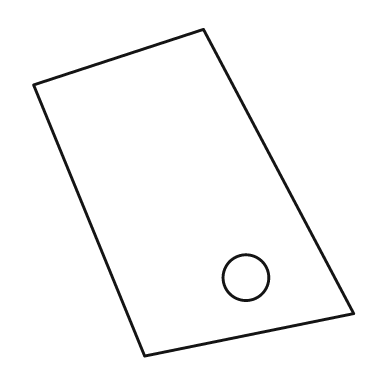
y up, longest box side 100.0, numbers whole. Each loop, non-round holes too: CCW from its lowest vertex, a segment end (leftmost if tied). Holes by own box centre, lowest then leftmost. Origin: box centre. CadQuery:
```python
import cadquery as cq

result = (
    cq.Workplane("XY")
    .moveTo(-15.0, -50.0)
    .lineTo(49.0, -37.0)
    .lineTo(3.0, 50.0)
    .lineTo(-49.0, 33.0)
    .close()
    .moveTo(16.0, -26.0)
    .circle(7.0)
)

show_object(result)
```